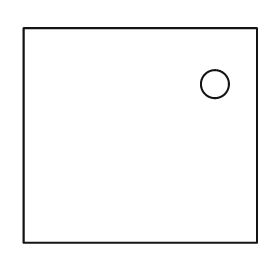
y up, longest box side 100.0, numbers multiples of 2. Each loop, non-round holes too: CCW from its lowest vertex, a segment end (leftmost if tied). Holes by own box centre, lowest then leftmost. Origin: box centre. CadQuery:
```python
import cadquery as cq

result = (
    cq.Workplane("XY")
    .moveTo(-50.0, -46.0)
    .lineTo(50.0, -46.0)
    .lineTo(50.0, 46.0)
    .lineTo(-50.0, 46.0)
    .close()
    .moveTo(32.0, 22.0)
    .circle(6.0)
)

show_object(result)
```